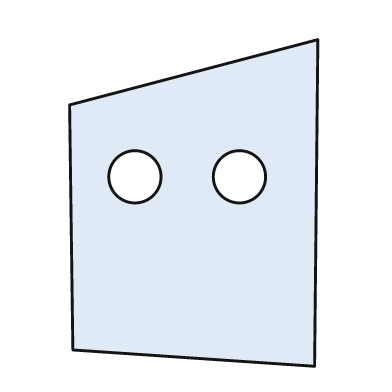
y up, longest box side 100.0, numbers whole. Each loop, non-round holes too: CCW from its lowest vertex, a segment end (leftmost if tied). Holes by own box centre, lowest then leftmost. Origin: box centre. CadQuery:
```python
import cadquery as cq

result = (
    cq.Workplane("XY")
    .moveTo(37.0, -50.0)
    .lineTo(38.0, 50.0)
    .lineTo(-38.0, 30.0)
    .lineTo(-37.0, -45.0)
    .close()
    .moveTo(-18.0, 8.0)
    .circle(8.0)
    .moveTo(14.0, 8.0)
    .circle(8.0)
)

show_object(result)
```